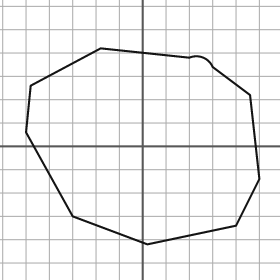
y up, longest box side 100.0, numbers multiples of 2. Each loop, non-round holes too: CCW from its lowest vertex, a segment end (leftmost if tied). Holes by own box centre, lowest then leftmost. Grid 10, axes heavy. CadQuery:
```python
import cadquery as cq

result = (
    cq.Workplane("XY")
    .moveTo(2.0, -42.0)
    .lineTo(40.0, -34.0)
    .lineTo(50.0, -14.0)
    .lineTo(46.0, 22.0)
    .lineTo(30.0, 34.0)
    .threePointArc((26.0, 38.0), (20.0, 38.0))
    .lineTo(-18.0, 42.0)
    .lineTo(-48.0, 26.0)
    .lineTo(-50.0, 6.0)
    .lineTo(-30.0, -30.0)
    .close()
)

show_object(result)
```